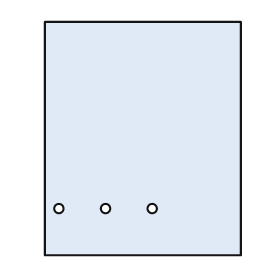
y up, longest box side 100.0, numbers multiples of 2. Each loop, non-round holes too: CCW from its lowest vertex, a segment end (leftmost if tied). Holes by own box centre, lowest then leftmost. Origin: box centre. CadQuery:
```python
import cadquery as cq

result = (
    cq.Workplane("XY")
    .moveTo(-42.0, -50.0)
    .lineTo(42.0, -50.0)
    .lineTo(42.0, 50.0)
    .lineTo(-42.0, 50.0)
    .close()
    .moveTo(-36.0, -30.0)
    .circle(2.0)
    .moveTo(-16.0, -30.0)
    .circle(2.0)
    .moveTo(4.0, -30.0)
    .circle(2.0)
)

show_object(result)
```